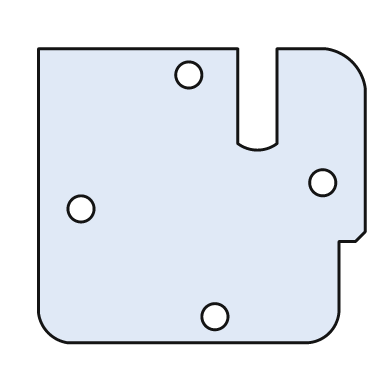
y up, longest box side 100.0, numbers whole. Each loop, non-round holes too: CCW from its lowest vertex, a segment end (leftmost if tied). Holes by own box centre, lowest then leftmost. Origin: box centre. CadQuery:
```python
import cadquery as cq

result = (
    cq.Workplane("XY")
    .moveTo(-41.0, -45.0)
    .lineTo(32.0, -45.0)
    .threePointArc((39.0, -42.0), (42.0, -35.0))
    .lineTo(42.0, -14.0)
    .lineTo(47.0, -14.0)
    .lineTo(50.0, -11.0)
    .lineTo(50.0, 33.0)
    .threePointArc((46.0, 41.0), (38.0, 45.0))
    .lineTo(23.0, 45.0)
    .lineTo(23.0, 16.0)
    .threePointArc((17.0, 14.0), (11.0, 16.0))
    .lineTo(11.0, 45.0)
    .lineTo(-50.0, 45.0)
    .lineTo(-50.0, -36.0)
    .threePointArc((-47.0, -42.0), (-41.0, -45.0))
    .close()
    .moveTo(4.0, -37.0)
    .circle(4.0)
    .moveTo(-37.0, -4.0)
    .circle(4.0)
    .moveTo(37.0, 4.0)
    .circle(4.0)
    .moveTo(-4.0, 37.0)
    .circle(4.0)
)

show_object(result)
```